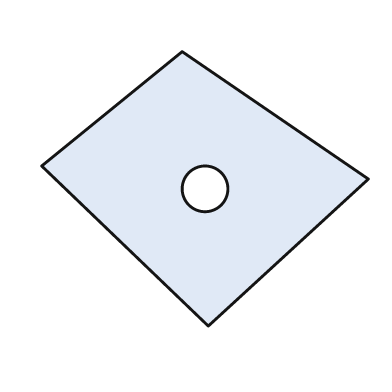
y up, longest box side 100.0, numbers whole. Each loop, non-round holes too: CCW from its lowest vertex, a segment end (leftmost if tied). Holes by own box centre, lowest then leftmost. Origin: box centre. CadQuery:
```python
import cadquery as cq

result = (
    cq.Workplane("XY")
    .moveTo(1.0, -42.0)
    .lineTo(50.0, 3.0)
    .lineTo(-7.0, 42.0)
    .lineTo(-50.0, 7.0)
    .close()
    .moveTo(0.0, 0.0)
    .circle(7.0)
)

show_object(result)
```